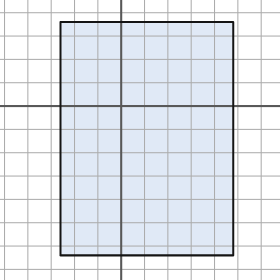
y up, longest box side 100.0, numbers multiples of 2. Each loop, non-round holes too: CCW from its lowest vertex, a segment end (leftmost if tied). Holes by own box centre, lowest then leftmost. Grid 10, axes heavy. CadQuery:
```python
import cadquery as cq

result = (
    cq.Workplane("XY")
    .moveTo(-26.0, -64.0)
    .lineTo(48.0, -64.0)
    .lineTo(48.0, 36.0)
    .lineTo(-26.0, 36.0)
    .close()
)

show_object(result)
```